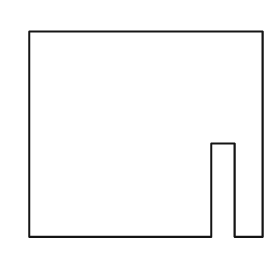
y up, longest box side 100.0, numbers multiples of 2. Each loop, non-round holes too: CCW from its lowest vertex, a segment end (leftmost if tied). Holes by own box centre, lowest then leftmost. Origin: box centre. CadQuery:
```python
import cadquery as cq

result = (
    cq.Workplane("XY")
    .moveTo(-50.0, -44.0)
    .lineTo(28.0, -44.0)
    .lineTo(28.0, -4.0)
    .lineTo(38.0, -4.0)
    .lineTo(38.0, -44.0)
    .lineTo(50.0, -44.0)
    .lineTo(50.0, 44.0)
    .lineTo(-50.0, 44.0)
    .close()
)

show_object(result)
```